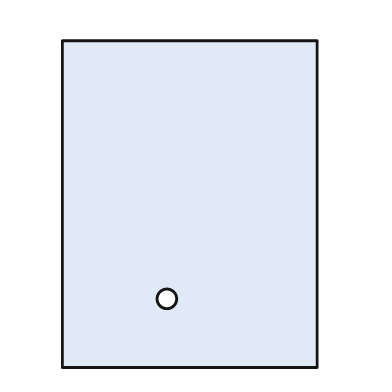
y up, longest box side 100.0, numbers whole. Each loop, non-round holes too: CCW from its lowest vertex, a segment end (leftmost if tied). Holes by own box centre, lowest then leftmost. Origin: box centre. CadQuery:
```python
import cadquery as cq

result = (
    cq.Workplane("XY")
    .moveTo(-39.0, -50.0)
    .lineTo(39.0, -50.0)
    .lineTo(39.0, 50.0)
    .lineTo(-39.0, 50.0)
    .close()
    .moveTo(-7.0, -29.0)
    .circle(3.0)
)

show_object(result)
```